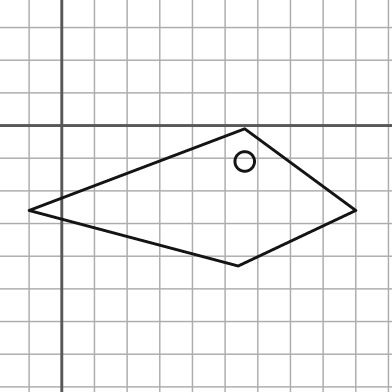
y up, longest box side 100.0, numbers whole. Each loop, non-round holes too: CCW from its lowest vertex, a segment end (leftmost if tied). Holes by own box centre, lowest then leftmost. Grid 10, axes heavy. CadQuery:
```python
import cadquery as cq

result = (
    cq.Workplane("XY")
    .moveTo(54.0, -43.0)
    .lineTo(90.0, -26.0)
    .lineTo(56.0, -1.0)
    .lineTo(-10.0, -26.0)
    .close()
    .moveTo(56.0, -11.0)
    .circle(3.0)
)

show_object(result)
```